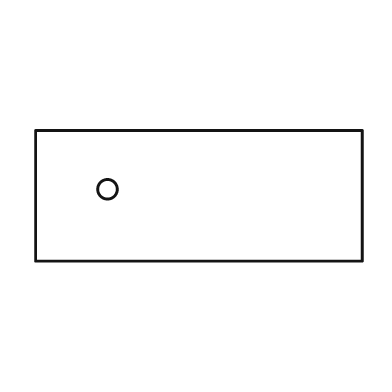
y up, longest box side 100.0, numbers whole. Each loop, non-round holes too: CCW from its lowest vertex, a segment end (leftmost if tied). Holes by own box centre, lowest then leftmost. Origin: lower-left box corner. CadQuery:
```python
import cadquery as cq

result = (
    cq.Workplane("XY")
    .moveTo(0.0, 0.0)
    .lineTo(100.0, 0.0)
    .lineTo(100.0, 40.0)
    .lineTo(0.0, 40.0)
    .close()
    .moveTo(22.0, 22.0)
    .circle(3.0)
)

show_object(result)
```